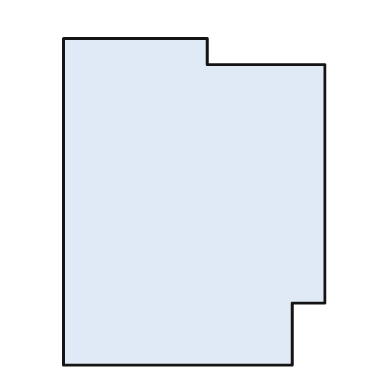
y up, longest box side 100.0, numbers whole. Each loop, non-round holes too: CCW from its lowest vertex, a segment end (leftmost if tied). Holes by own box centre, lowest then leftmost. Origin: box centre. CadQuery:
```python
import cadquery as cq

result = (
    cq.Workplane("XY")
    .moveTo(-40.0, -50.0)
    .lineTo(30.0, -50.0)
    .lineTo(30.0, -31.0)
    .lineTo(40.0, -31.0)
    .lineTo(40.0, 42.0)
    .lineTo(4.0, 42.0)
    .lineTo(4.0, 50.0)
    .lineTo(-40.0, 50.0)
    .close()
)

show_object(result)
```